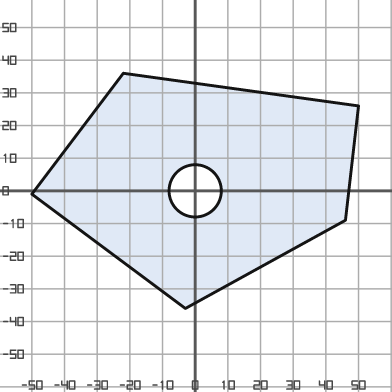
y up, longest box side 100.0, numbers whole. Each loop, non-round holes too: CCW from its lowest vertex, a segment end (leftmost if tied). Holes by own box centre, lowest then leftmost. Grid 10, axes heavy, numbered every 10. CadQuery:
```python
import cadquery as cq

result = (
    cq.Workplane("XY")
    .moveTo(-3.0, -36.0)
    .lineTo(46.0, -9.0)
    .lineTo(50.0, 26.0)
    .lineTo(-22.0, 36.0)
    .lineTo(-50.0, -1.0)
    .close()
    .moveTo(0.0, 0.0)
    .circle(8.0)
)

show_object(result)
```